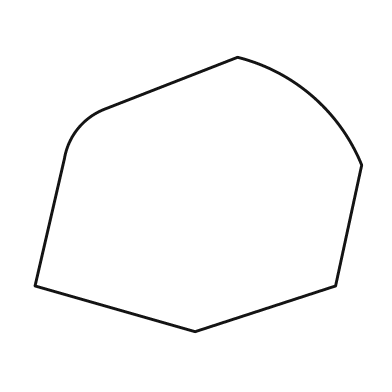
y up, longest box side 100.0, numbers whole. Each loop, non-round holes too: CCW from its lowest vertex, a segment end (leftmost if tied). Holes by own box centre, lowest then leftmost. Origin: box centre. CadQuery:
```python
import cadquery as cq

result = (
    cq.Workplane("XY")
    .moveTo(-1.0, -42.0)
    .lineTo(42.0, -28.0)
    .lineTo(50.0, 9.0)
    .threePointArc((35.0, 30.0), (12.0, 42.0))
    .lineTo(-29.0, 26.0)
    .threePointArc((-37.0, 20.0), (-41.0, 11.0))
    .lineTo(-50.0, -28.0)
    .close()
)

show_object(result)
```